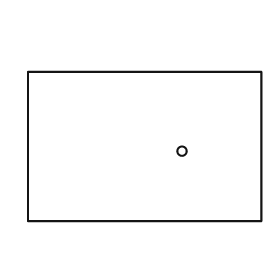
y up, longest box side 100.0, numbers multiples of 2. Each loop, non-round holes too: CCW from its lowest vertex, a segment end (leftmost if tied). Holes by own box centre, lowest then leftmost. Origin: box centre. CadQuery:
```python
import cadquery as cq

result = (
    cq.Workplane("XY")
    .moveTo(-50.0, -32.0)
    .lineTo(50.0, -32.0)
    .lineTo(50.0, 32.0)
    .lineTo(-50.0, 32.0)
    .close()
    .moveTo(16.0, -2.0)
    .circle(2.0)
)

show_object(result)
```